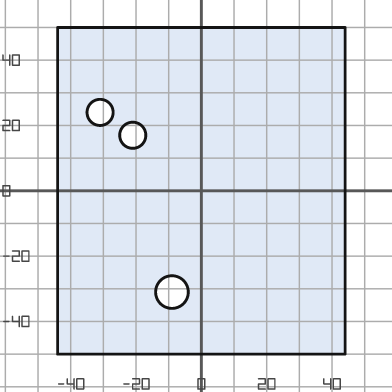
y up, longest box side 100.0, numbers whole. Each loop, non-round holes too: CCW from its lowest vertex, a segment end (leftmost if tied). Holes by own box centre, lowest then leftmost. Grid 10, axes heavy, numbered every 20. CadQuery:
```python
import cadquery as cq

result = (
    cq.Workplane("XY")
    .moveTo(-44.0, -50.0)
    .lineTo(44.0, -50.0)
    .lineTo(44.0, 50.0)
    .lineTo(-44.0, 50.0)
    .close()
    .moveTo(-9.0, -31.0)
    .circle(5.0)
    .moveTo(-21.0, 17.0)
    .circle(4.0)
    .moveTo(-31.0, 24.0)
    .circle(4.0)
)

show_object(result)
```